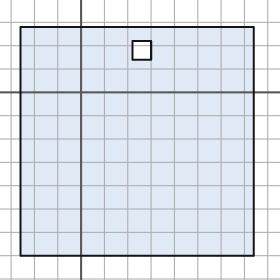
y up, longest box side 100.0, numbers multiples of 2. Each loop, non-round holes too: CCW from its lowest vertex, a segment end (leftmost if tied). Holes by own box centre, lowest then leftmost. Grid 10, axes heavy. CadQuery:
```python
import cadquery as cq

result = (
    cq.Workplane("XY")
    .moveTo(-26.0, -70.0)
    .lineTo(74.0, -70.0)
    .lineTo(74.0, 28.0)
    .lineTo(-26.0, 28.0)
    .close()
    .moveTo(22.0, 14.0)
    .lineTo(30.0, 14.0)
    .lineTo(30.0, 22.0)
    .lineTo(22.0, 22.0)
    .close()
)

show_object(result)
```